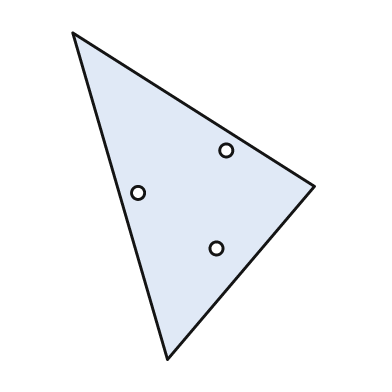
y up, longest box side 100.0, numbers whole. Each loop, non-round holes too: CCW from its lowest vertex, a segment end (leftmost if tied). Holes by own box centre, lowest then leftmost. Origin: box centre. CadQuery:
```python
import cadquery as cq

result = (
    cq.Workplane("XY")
    .moveTo(-8.0, -50.0)
    .lineTo(37.0, 3.0)
    .lineTo(-37.0, 50.0)
    .close()
    .moveTo(7.0, -16.0)
    .circle(2.0)
    .moveTo(-17.0, 1.0)
    .circle(2.0)
    .moveTo(10.0, 14.0)
    .circle(2.0)
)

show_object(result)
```